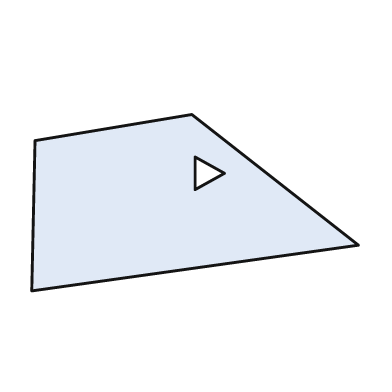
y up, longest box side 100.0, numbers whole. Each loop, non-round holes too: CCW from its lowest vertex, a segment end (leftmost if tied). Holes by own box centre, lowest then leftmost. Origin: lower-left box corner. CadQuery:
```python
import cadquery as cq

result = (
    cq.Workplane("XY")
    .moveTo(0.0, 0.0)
    .lineTo(100.0, 14.0)
    .lineTo(49.0, 54.0)
    .lineTo(1.0, 46.0)
    .close()
    .moveTo(50.0, 31.0)
    .lineTo(59.0, 36.0)
    .lineTo(50.0, 41.0)
    .close()
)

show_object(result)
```